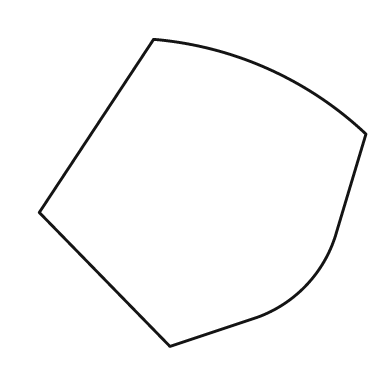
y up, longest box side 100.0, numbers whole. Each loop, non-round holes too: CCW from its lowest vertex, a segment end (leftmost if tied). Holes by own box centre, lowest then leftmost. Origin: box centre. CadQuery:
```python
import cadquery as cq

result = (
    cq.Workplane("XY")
    .moveTo(-10.0, -47.0)
    .lineTo(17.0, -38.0)
    .threePointArc((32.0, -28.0), (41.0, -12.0))
    .lineTo(50.0, 18.0)
    .threePointArc((20.0, 38.0), (-15.0, 47.0))
    .lineTo(-50.0, -6.0)
    .close()
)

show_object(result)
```